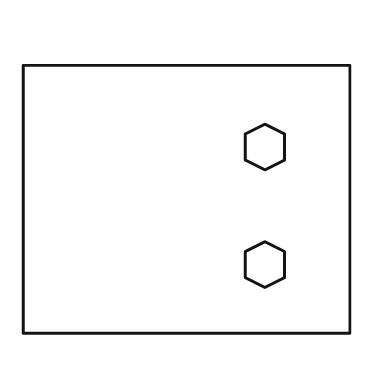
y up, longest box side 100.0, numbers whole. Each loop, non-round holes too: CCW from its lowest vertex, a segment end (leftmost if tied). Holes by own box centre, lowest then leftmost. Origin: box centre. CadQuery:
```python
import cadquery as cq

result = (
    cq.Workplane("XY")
    .moveTo(-50.0, -41.0)
    .lineTo(50.0, -41.0)
    .lineTo(50.0, 41.0)
    .lineTo(-50.0, 41.0)
    .close()
    .moveTo(24.0, -27.0)
    .lineTo(30.0, -24.0)
    .lineTo(30.0, -16.0)
    .lineTo(24.0, -13.0)
    .lineTo(18.0, -16.0)
    .lineTo(18.0, -24.0)
    .close()
    .moveTo(24.0, 9.0)
    .lineTo(30.0, 12.0)
    .lineTo(30.0, 20.0)
    .lineTo(24.0, 23.0)
    .lineTo(18.0, 20.0)
    .lineTo(18.0, 12.0)
    .close()
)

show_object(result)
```